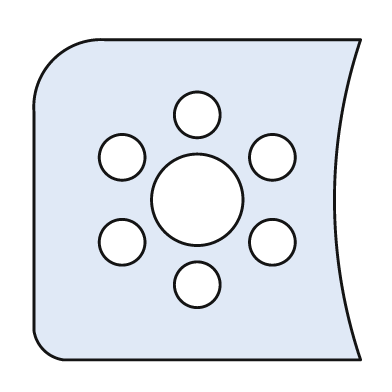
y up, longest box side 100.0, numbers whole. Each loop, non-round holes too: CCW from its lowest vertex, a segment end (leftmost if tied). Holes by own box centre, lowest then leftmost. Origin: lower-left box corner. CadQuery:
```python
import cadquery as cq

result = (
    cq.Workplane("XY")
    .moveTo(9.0, 0.0)
    .lineTo(100.0, 0.0)
    .threePointArc((92.0, 49.0), (100.0, 98.0))
    .lineTo(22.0, 98.0)
    .threePointArc((6.0, 92.0), (0.0, 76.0))
    .lineTo(0.0, 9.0)
    .threePointArc((3.0, 3.0), (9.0, 0.0))
    .close()
    .moveTo(50.0, 23.0)
    .circle(7.0)
    .moveTo(27.0, 36.0)
    .circle(7.0)
    .moveTo(73.0, 36.0)
    .circle(7.0)
    .moveTo(50.0, 49.0)
    .circle(14.0)
    .moveTo(27.0, 62.0)
    .circle(7.0)
    .moveTo(73.0, 62.0)
    .circle(7.0)
    .moveTo(50.0, 75.0)
    .circle(7.0)
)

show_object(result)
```